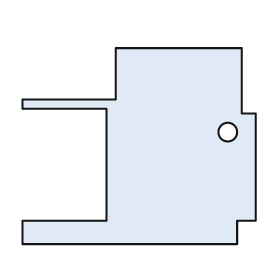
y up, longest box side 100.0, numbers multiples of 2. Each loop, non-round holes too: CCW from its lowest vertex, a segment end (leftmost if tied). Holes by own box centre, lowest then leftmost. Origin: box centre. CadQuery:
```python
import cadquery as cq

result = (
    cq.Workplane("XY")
    .moveTo(-50.0, -42.0)
    .lineTo(42.0, -42.0)
    .lineTo(42.0, -32.0)
    .lineTo(50.0, -32.0)
    .lineTo(50.0, 14.0)
    .lineTo(44.0, 14.0)
    .lineTo(44.0, 42.0)
    .lineTo(-10.0, 42.0)
    .lineTo(-10.0, 20.0)
    .lineTo(-50.0, 20.0)
    .lineTo(-50.0, 16.0)
    .lineTo(-14.0, 16.0)
    .lineTo(-14.0, -32.0)
    .lineTo(-50.0, -32.0)
    .close()
    .moveTo(38.0, 6.0)
    .circle(4.0)
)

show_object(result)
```